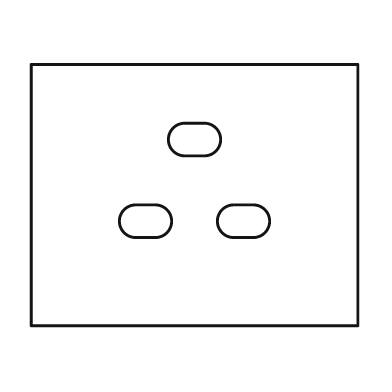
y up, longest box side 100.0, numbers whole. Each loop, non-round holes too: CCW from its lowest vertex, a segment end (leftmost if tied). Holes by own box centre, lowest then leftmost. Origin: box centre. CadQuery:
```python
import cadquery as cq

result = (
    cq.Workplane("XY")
    .moveTo(-50.0, -40.0)
    .lineTo(50.0, -40.0)
    .lineTo(50.0, 40.0)
    .lineTo(-50.0, 40.0)
    .close()
    .moveTo(-18.0, -13.0)
    .lineTo(-12.0, -13.0)
    .threePointArc((-7.0, -8.0), (-12.0, -3.0))
    .lineTo(-18.0, -3.0)
    .threePointArc((-23.0, -8.0), (-18.0, -13.0))
    .close()
    .moveTo(12.0, -13.0)
    .lineTo(18.0, -13.0)
    .threePointArc((23.0, -8.0), (18.0, -3.0))
    .lineTo(12.0, -3.0)
    .threePointArc((7.0, -8.0), (12.0, -13.0))
    .close()
    .moveTo(-3.0, 12.0)
    .lineTo(3.0, 12.0)
    .threePointArc((8.0, 17.0), (3.0, 22.0))
    .lineTo(-3.0, 22.0)
    .threePointArc((-8.0, 17.0), (-3.0, 12.0))
    .close()
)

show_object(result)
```